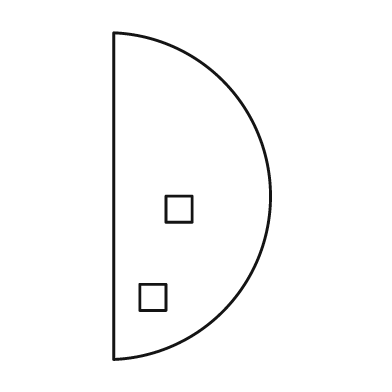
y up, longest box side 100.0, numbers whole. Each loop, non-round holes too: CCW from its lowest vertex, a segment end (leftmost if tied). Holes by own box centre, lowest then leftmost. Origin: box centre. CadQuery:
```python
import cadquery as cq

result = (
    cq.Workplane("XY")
    .moveTo(-24.0, -50.0)
    .threePointArc((24.0, 0.0), (-24.0, 50.0))
    .close()
    .moveTo(-16.0, -35.0)
    .lineTo(-8.0, -35.0)
    .lineTo(-8.0, -27.0)
    .lineTo(-16.0, -27.0)
    .close()
    .moveTo(-8.0, -8.0)
    .lineTo(0.0, -8.0)
    .lineTo(0.0, 0.0)
    .lineTo(-8.0, 0.0)
    .close()
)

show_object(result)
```